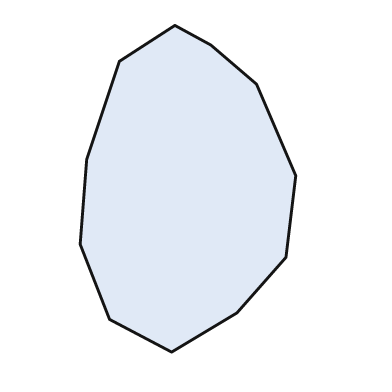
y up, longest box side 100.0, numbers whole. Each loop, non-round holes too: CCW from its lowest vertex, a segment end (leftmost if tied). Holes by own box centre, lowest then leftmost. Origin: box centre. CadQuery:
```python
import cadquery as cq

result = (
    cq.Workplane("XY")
    .moveTo(-5.0, -50.0)
    .lineTo(15.0, -38.0)
    .lineTo(30.0, -21.0)
    .lineTo(33.0, 4.0)
    .lineTo(21.0, 32.0)
    .lineTo(7.0, 44.0)
    .lineTo(-4.0, 50.0)
    .lineTo(-21.0, 39.0)
    .lineTo(-31.0, 9.0)
    .lineTo(-33.0, -17.0)
    .lineTo(-24.0, -40.0)
    .close()
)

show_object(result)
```